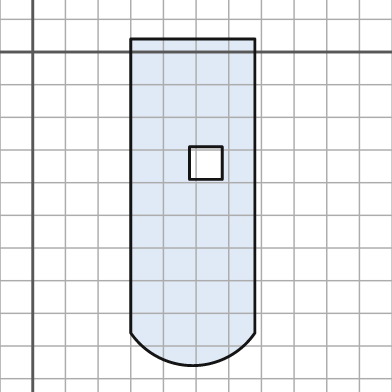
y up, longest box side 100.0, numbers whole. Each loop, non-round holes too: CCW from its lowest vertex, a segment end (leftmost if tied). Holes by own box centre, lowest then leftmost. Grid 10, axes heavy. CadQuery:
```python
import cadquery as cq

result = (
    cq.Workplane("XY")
    .moveTo(30.0, -86.0)
    .threePointArc((49.0, -96.0), (68.0, -86.0))
    .lineTo(68.0, 4.0)
    .lineTo(30.0, 4.0)
    .close()
    .moveTo(48.0, -39.0)
    .lineTo(58.0, -39.0)
    .lineTo(58.0, -29.0)
    .lineTo(48.0, -29.0)
    .close()
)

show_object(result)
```